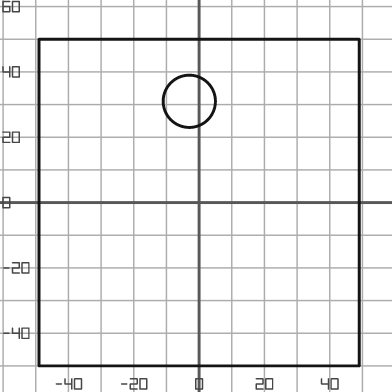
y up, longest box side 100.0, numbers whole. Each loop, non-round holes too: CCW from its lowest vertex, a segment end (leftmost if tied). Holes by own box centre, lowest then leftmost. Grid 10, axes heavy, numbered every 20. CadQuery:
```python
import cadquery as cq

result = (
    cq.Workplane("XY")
    .moveTo(-49.0, -50.0)
    .lineTo(49.0, -50.0)
    .lineTo(49.0, 50.0)
    .lineTo(-49.0, 50.0)
    .close()
    .moveTo(-3.0, 31.0)
    .circle(8.0)
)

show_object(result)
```